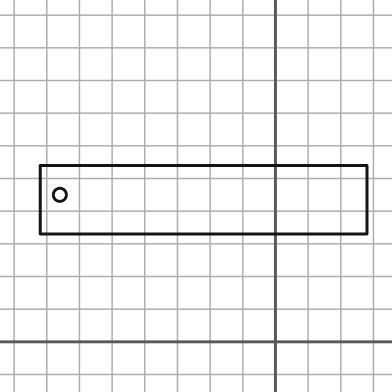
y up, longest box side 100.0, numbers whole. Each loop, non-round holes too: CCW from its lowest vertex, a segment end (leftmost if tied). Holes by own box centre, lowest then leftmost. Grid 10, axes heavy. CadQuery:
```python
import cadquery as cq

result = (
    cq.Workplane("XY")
    .moveTo(-72.0, 33.0)
    .lineTo(28.0, 33.0)
    .lineTo(28.0, 54.0)
    .lineTo(-72.0, 54.0)
    .close()
    .moveTo(-66.0, 45.0)
    .circle(2.0)
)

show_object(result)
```